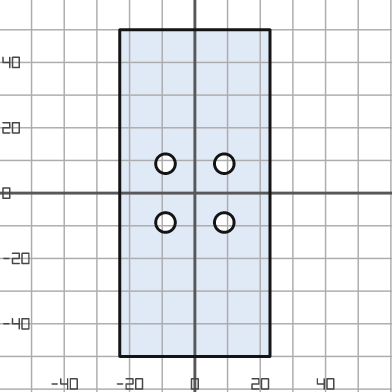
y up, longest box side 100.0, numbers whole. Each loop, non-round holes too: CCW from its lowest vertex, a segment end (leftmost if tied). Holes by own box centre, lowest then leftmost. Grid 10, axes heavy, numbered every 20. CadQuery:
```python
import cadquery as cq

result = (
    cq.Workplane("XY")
    .moveTo(-23.0, -50.0)
    .lineTo(23.0, -50.0)
    .lineTo(23.0, 50.0)
    .lineTo(-23.0, 50.0)
    .close()
    .moveTo(-9.0, -9.0)
    .circle(3.0)
    .moveTo(9.0, -9.0)
    .circle(3.0)
    .moveTo(-9.0, 9.0)
    .circle(3.0)
    .moveTo(9.0, 9.0)
    .circle(3.0)
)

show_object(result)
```